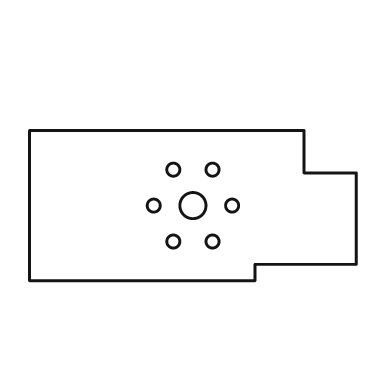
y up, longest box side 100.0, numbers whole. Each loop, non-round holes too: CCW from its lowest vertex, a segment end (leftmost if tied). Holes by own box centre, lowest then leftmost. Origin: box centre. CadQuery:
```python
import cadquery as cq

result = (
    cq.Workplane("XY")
    .moveTo(-50.0, -23.0)
    .lineTo(19.0, -23.0)
    .lineTo(19.0, -18.0)
    .lineTo(50.0, -18.0)
    .lineTo(50.0, 10.0)
    .lineTo(34.0, 10.0)
    .lineTo(34.0, 23.0)
    .lineTo(-50.0, 23.0)
    .close()
    .moveTo(-6.0, -11.0)
    .circle(2.0)
    .moveTo(6.0, -11.0)
    .circle(2.0)
    .moveTo(-12.0, 0.0)
    .circle(2.0)
    .moveTo(0.0, 0.0)
    .circle(4.0)
    .moveTo(12.0, 0.0)
    .circle(2.0)
    .moveTo(-6.0, 11.0)
    .circle(2.0)
    .moveTo(6.0, 11.0)
    .circle(2.0)
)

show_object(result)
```